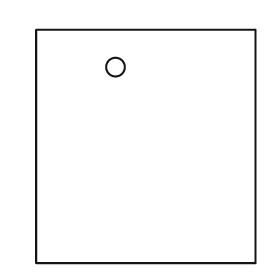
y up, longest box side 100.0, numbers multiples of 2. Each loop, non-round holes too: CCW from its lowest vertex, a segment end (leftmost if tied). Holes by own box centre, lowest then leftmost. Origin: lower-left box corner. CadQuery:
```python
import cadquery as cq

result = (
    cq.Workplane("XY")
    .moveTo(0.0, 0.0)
    .lineTo(94.0, 0.0)
    .lineTo(94.0, 100.0)
    .lineTo(0.0, 100.0)
    .close()
    .moveTo(34.0, 84.0)
    .circle(4.0)
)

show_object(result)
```